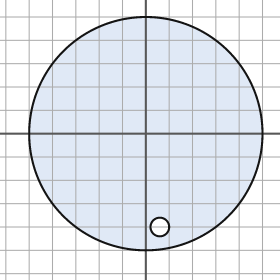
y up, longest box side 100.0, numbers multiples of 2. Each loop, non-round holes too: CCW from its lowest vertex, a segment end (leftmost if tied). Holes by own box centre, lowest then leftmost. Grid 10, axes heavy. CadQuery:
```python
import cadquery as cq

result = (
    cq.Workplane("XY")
    .moveTo(0.0, 0.0)
    .circle(50.0)
    .moveTo(6.0, -40.0)
    .circle(4.0)
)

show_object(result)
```